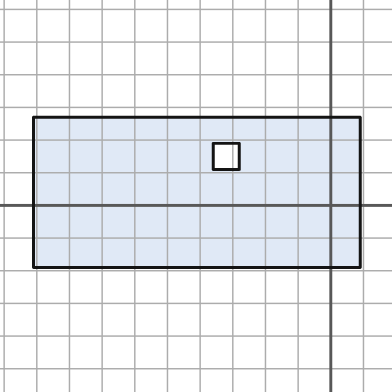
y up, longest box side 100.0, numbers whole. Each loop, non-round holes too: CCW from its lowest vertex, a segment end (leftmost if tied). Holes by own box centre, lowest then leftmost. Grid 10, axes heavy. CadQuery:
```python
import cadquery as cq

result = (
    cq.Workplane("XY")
    .moveTo(-91.0, -19.0)
    .lineTo(9.0, -19.0)
    .lineTo(9.0, 27.0)
    .lineTo(-91.0, 27.0)
    .close()
    .moveTo(-36.0, 11.0)
    .lineTo(-28.0, 11.0)
    .lineTo(-28.0, 19.0)
    .lineTo(-36.0, 19.0)
    .close()
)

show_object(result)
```